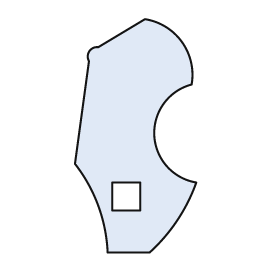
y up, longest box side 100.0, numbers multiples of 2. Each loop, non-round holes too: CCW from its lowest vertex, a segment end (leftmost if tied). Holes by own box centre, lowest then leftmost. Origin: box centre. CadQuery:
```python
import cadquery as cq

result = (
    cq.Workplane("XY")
    .moveTo(-12.0, -50.0)
    .lineTo(6.0, -50.0)
    .threePointArc((18.0, -36.0), (26.0, -20.0))
    .threePointArc((8.0, 0.0), (24.0, 22.0))
    .threePointArc((20.0, 40.0), (4.0, 50.0))
    .lineTo(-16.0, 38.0)
    .threePointArc((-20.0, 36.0), (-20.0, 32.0))
    .lineTo(-26.0, -12.0)
    .threePointArc((-16.0, -30.0), (-12.0, -50.0))
    .close()
    .moveTo(-10.0, -32.0)
    .lineTo(2.0, -32.0)
    .lineTo(2.0, -20.0)
    .lineTo(-10.0, -20.0)
    .close()
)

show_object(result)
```